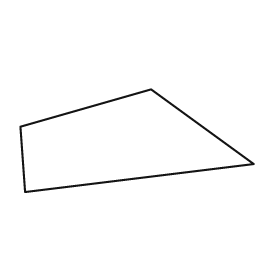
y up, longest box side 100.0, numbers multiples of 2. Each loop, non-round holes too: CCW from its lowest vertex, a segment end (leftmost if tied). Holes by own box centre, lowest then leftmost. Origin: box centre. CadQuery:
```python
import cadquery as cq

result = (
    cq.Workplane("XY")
    .moveTo(-48.0, -22.0)
    .lineTo(50.0, -10.0)
    .lineTo(6.0, 22.0)
    .lineTo(-50.0, 6.0)
    .close()
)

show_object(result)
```